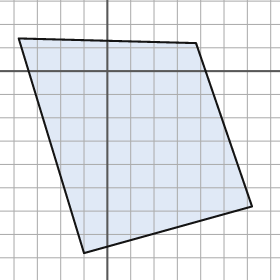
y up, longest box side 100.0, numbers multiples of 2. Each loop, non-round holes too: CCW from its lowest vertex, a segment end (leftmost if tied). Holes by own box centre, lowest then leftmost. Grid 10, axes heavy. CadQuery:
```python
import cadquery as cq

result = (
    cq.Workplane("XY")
    .moveTo(-10.0, -78.0)
    .lineTo(62.0, -58.0)
    .lineTo(38.0, 12.0)
    .lineTo(-38.0, 14.0)
    .close()
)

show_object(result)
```